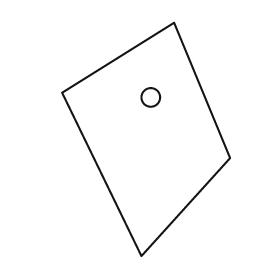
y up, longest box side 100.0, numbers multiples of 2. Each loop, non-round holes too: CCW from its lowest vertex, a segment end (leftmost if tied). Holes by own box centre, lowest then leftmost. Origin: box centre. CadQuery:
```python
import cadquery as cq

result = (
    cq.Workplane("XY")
    .moveTo(-2.0, -50.0)
    .lineTo(36.0, -8.0)
    .lineTo(12.0, 50.0)
    .lineTo(-36.0, 20.0)
    .close()
    .moveTo(2.0, 18.0)
    .circle(4.0)
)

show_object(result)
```